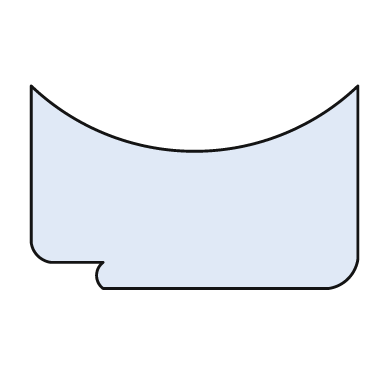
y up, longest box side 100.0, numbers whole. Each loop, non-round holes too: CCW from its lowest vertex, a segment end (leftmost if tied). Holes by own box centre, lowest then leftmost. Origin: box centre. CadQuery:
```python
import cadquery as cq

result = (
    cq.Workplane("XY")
    .moveTo(-28.0, -31.0)
    .lineTo(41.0, -31.0)
    .threePointArc((47.0, -28.0), (50.0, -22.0))
    .lineTo(50.0, 31.0)
    .threePointArc((0.0, 11.0), (-50.0, 31.0))
    .lineTo(-50.0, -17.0)
    .threePointArc((-48.0, -21.0), (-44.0, -23.0))
    .lineTo(-28.0, -23.0)
    .threePointArc((-30.0, -27.0), (-28.0, -31.0))
    .close()
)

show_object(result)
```